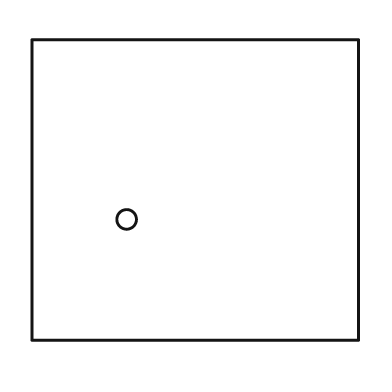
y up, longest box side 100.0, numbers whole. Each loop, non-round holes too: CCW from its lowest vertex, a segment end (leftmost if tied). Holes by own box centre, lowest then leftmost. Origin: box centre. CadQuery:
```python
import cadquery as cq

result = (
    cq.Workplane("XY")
    .moveTo(-50.0, -46.0)
    .lineTo(50.0, -46.0)
    .lineTo(50.0, 46.0)
    .lineTo(-50.0, 46.0)
    .close()
    .moveTo(-21.0, -9.0)
    .circle(3.0)
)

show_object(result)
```